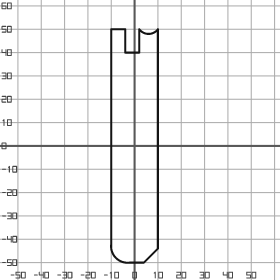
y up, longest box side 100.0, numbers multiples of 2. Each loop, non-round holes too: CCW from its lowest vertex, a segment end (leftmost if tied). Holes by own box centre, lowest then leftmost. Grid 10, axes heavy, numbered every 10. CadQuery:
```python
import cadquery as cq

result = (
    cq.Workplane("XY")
    .moveTo(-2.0, -50.0)
    .lineTo(4.0, -50.0)
    .lineTo(10.0, -44.0)
    .lineTo(10.0, 50.0)
    .threePointArc((6.0, 48.0), (2.0, 50.0))
    .lineTo(2.0, 40.0)
    .lineTo(-4.0, 40.0)
    .lineTo(-4.0, 50.0)
    .lineTo(-10.0, 50.0)
    .lineTo(-10.0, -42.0)
    .threePointArc((-8.0, -48.0), (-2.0, -50.0))
    .close()
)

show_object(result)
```